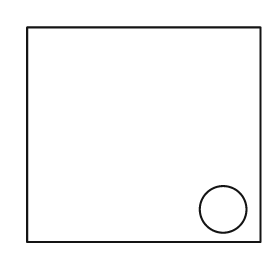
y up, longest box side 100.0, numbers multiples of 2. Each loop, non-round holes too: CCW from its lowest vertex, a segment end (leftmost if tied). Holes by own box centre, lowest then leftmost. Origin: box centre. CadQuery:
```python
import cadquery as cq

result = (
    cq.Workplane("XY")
    .moveTo(-50.0, -46.0)
    .lineTo(50.0, -46.0)
    .lineTo(50.0, 46.0)
    .lineTo(-50.0, 46.0)
    .close()
    .moveTo(34.0, -32.0)
    .circle(10.0)
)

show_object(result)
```